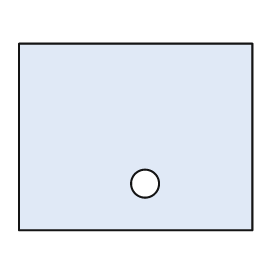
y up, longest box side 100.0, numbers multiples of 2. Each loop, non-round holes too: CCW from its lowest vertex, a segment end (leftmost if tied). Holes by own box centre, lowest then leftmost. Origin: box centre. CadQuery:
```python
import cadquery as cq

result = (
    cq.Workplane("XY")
    .moveTo(-50.0, -40.0)
    .lineTo(50.0, -40.0)
    .lineTo(50.0, 40.0)
    .lineTo(-50.0, 40.0)
    .close()
    .moveTo(4.0, -20.0)
    .circle(6.0)
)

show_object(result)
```